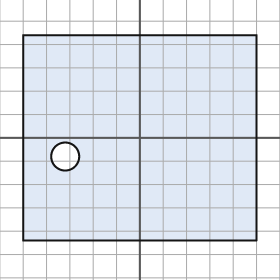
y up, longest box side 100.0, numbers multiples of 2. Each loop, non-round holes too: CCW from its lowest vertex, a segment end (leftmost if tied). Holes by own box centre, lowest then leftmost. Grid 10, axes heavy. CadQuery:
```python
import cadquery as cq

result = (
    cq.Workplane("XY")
    .moveTo(-50.0, -44.0)
    .lineTo(50.0, -44.0)
    .lineTo(50.0, 44.0)
    .lineTo(-50.0, 44.0)
    .close()
    .moveTo(-32.0, -8.0)
    .circle(6.0)
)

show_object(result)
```